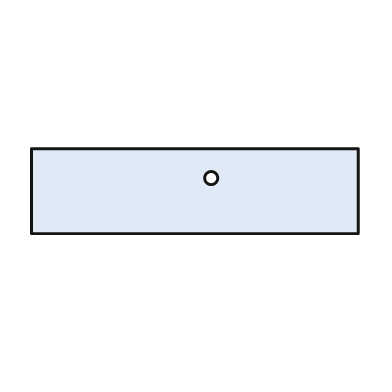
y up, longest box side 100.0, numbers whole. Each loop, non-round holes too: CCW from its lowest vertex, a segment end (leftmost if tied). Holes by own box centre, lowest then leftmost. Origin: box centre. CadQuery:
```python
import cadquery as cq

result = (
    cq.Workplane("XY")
    .moveTo(-50.0, -13.0)
    .lineTo(50.0, -13.0)
    .lineTo(50.0, 13.0)
    .lineTo(-50.0, 13.0)
    .close()
    .moveTo(5.0, 4.0)
    .circle(2.0)
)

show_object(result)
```